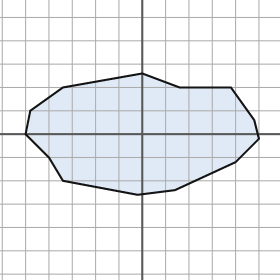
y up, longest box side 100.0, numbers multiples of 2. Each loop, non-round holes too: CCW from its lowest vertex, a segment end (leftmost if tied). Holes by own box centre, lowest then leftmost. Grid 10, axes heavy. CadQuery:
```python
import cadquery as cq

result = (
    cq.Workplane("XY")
    .moveTo(-2.0, -26.0)
    .lineTo(14.0, -24.0)
    .lineTo(40.0, -12.0)
    .lineTo(50.0, -2.0)
    .lineTo(48.0, 6.0)
    .lineTo(38.0, 20.0)
    .lineTo(16.0, 20.0)
    .lineTo(0.0, 26.0)
    .lineTo(-34.0, 20.0)
    .lineTo(-48.0, 10.0)
    .lineTo(-50.0, 0.0)
    .lineTo(-40.0, -10.0)
    .lineTo(-34.0, -20.0)
    .close()
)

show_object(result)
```